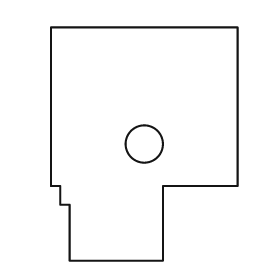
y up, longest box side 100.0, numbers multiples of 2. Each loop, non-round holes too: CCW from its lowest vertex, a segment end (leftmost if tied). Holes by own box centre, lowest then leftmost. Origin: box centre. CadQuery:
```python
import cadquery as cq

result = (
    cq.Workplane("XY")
    .moveTo(-32.0, -50.0)
    .lineTo(8.0, -50.0)
    .lineTo(8.0, -18.0)
    .lineTo(40.0, -18.0)
    .lineTo(40.0, 50.0)
    .lineTo(-40.0, 50.0)
    .lineTo(-40.0, -18.0)
    .lineTo(-36.0, -18.0)
    .lineTo(-36.0, -26.0)
    .lineTo(-32.0, -26.0)
    .close()
    .moveTo(0.0, 0.0)
    .circle(8.0)
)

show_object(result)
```